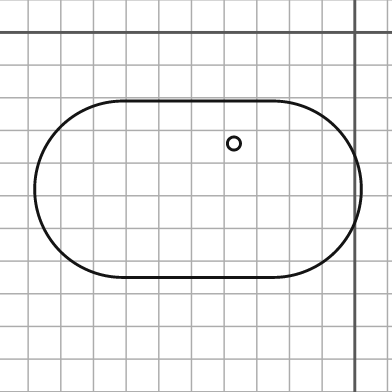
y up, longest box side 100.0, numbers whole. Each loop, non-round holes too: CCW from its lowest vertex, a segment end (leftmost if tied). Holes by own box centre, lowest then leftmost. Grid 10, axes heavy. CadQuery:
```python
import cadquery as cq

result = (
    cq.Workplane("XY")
    .moveTo(-71.0, -75.0)
    .lineTo(-25.0, -75.0)
    .threePointArc((2.0, -48.0), (-25.0, -21.0))
    .lineTo(-71.0, -21.0)
    .threePointArc((-98.0, -48.0), (-71.0, -75.0))
    .close()
    .moveTo(-37.0, -34.0)
    .circle(2.0)
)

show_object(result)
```